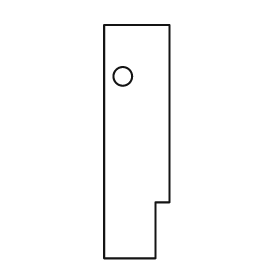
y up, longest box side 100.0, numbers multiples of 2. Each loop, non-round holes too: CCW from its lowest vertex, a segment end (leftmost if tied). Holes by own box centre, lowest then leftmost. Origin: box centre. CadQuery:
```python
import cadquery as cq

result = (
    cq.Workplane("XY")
    .moveTo(-14.0, -50.0)
    .lineTo(8.0, -50.0)
    .lineTo(8.0, -26.0)
    .lineTo(14.0, -26.0)
    .lineTo(14.0, 50.0)
    .lineTo(-14.0, 50.0)
    .close()
    .moveTo(-6.0, 28.0)
    .circle(4.0)
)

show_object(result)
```